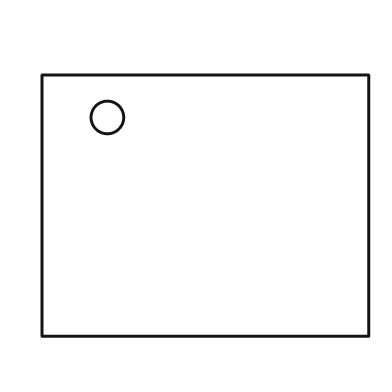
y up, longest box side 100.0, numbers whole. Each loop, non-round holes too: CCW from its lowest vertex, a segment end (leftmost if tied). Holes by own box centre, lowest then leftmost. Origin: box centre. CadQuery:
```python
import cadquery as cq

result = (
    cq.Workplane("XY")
    .moveTo(-50.0, -40.0)
    .lineTo(50.0, -40.0)
    .lineTo(50.0, 40.0)
    .lineTo(-50.0, 40.0)
    .close()
    .moveTo(-30.0, 27.0)
    .circle(5.0)
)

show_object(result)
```